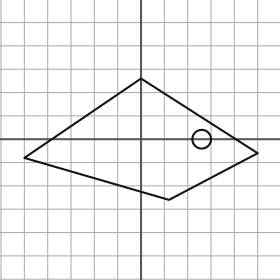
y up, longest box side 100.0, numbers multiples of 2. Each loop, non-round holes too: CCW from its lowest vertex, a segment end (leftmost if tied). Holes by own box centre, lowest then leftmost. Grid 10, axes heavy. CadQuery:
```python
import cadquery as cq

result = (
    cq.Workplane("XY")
    .moveTo(12.0, -26.0)
    .lineTo(50.0, -6.0)
    .lineTo(0.0, 26.0)
    .lineTo(-50.0, -8.0)
    .close()
    .moveTo(26.0, 0.0)
    .circle(4.0)
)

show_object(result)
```